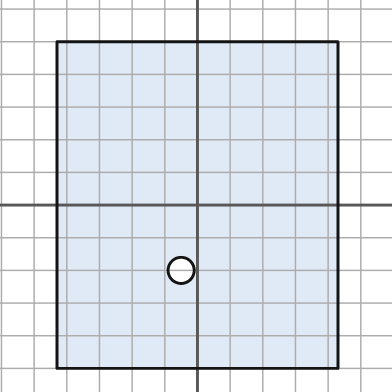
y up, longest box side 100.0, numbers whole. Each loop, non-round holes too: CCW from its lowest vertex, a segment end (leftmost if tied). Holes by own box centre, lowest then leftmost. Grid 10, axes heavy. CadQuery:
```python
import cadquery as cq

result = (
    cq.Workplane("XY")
    .moveTo(-43.0, -50.0)
    .lineTo(43.0, -50.0)
    .lineTo(43.0, 50.0)
    .lineTo(-43.0, 50.0)
    .close()
    .moveTo(-5.0, -20.0)
    .circle(4.0)
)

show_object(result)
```